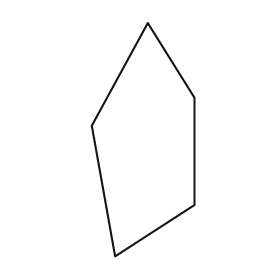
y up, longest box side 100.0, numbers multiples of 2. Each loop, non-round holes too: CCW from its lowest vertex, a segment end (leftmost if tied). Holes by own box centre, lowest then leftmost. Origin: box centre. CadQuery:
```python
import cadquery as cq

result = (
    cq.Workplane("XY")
    .moveTo(-12.0, -50.0)
    .lineTo(22.0, -28.0)
    .lineTo(22.0, 18.0)
    .lineTo(2.0, 50.0)
    .lineTo(-22.0, 6.0)
    .close()
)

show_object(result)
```